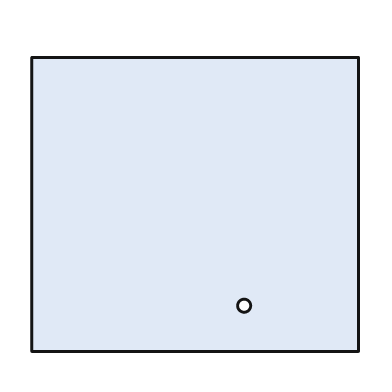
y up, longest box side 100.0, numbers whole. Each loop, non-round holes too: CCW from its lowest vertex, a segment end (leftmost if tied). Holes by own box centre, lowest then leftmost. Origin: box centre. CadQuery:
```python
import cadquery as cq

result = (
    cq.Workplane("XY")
    .moveTo(-50.0, -45.0)
    .lineTo(50.0, -45.0)
    .lineTo(50.0, 45.0)
    .lineTo(-50.0, 45.0)
    .close()
    .moveTo(15.0, -31.0)
    .circle(2.0)
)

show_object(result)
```